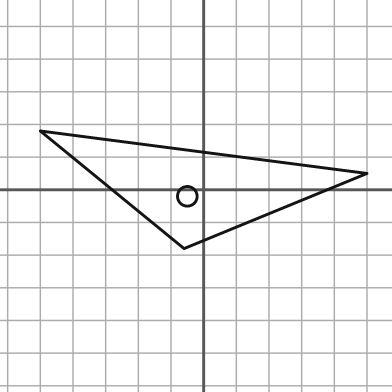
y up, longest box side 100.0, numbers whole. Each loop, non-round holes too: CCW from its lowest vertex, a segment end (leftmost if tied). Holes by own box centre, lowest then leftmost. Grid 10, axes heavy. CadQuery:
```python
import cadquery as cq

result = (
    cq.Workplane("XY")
    .moveTo(-6.0, -18.0)
    .lineTo(50.0, 5.0)
    .lineTo(-50.0, 18.0)
    .close()
    .moveTo(-5.0, -2.0)
    .circle(3.0)
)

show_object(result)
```